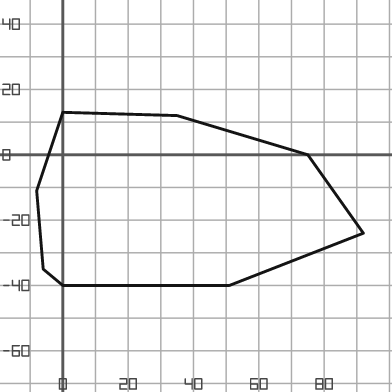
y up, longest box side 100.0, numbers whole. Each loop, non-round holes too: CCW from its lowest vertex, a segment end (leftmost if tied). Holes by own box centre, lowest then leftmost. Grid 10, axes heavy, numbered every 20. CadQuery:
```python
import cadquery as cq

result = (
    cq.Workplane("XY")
    .moveTo(0.0, -40.0)
    .lineTo(51.0, -40.0)
    .lineTo(92.0, -24.0)
    .lineTo(75.0, 0.0)
    .lineTo(35.0, 12.0)
    .lineTo(0.0, 13.0)
    .lineTo(-8.0, -11.0)
    .lineTo(-6.0, -35.0)
    .close()
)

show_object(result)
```